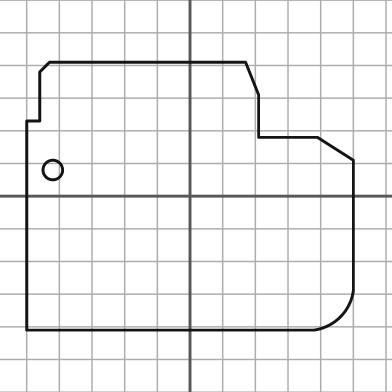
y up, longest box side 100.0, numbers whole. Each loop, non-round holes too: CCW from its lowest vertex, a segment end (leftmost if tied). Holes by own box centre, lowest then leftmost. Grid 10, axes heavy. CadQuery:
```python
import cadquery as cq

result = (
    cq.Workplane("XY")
    .moveTo(-50.0, -41.0)
    .lineTo(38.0, -41.0)
    .threePointArc((46.0, -37.0), (50.0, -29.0))
    .lineTo(50.0, 11.0)
    .lineTo(39.0, 18.0)
    .lineTo(21.0, 18.0)
    .lineTo(21.0, 31.0)
    .lineTo(17.0, 41.0)
    .lineTo(-43.0, 41.0)
    .lineTo(-46.0, 38.0)
    .lineTo(-46.0, 23.0)
    .lineTo(-50.0, 23.0)
    .close()
    .moveTo(-42.0, 8.0)
    .circle(3.0)
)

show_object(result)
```